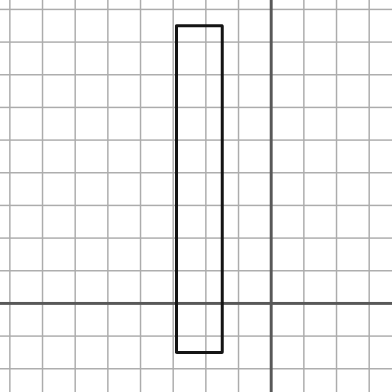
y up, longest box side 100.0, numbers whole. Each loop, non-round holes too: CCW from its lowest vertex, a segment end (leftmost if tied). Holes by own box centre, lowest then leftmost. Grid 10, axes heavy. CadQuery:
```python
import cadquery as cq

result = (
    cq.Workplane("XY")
    .moveTo(-29.0, -15.0)
    .lineTo(-15.0, -15.0)
    .lineTo(-15.0, 85.0)
    .lineTo(-29.0, 85.0)
    .close()
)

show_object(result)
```